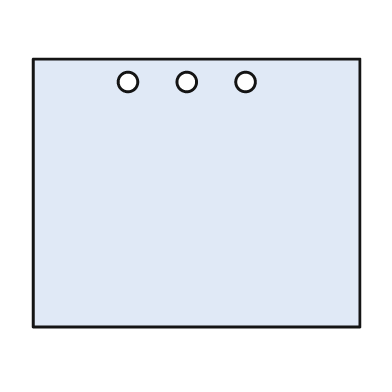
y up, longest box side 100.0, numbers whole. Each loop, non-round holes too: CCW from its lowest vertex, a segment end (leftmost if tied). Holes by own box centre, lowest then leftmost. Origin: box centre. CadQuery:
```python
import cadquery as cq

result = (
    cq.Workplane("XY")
    .moveTo(-50.0, -41.0)
    .lineTo(50.0, -41.0)
    .lineTo(50.0, 41.0)
    .lineTo(-50.0, 41.0)
    .close()
    .moveTo(-21.0, 34.0)
    .circle(3.0)
    .moveTo(-3.0, 34.0)
    .circle(3.0)
    .moveTo(15.0, 34.0)
    .circle(3.0)
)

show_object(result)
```